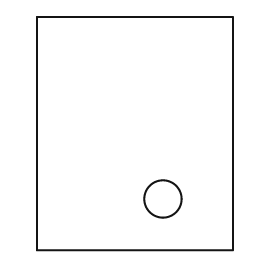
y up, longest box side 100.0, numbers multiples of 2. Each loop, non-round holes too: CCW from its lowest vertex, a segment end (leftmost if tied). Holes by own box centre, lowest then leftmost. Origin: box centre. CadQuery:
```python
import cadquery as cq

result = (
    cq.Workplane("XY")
    .moveTo(-42.0, -50.0)
    .lineTo(42.0, -50.0)
    .lineTo(42.0, 50.0)
    .lineTo(-42.0, 50.0)
    .close()
    .moveTo(12.0, -28.0)
    .circle(8.0)
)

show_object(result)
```